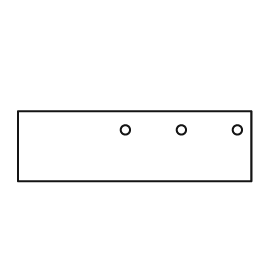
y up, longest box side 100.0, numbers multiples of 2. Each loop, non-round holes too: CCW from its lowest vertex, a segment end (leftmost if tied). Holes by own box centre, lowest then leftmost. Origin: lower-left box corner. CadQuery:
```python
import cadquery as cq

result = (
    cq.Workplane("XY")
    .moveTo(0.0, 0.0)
    .lineTo(100.0, 0.0)
    .lineTo(100.0, 30.0)
    .lineTo(0.0, 30.0)
    .close()
    .moveTo(46.0, 22.0)
    .circle(2.0)
    .moveTo(70.0, 22.0)
    .circle(2.0)
    .moveTo(94.0, 22.0)
    .circle(2.0)
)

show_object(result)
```